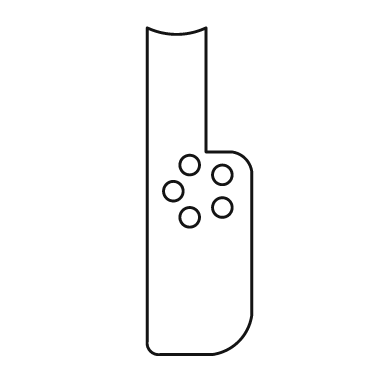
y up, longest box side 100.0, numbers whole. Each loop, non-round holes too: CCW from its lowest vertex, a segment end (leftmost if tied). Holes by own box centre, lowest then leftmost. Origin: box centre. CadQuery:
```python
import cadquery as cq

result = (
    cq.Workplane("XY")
    .moveTo(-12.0, -50.0)
    .lineTo(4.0, -50.0)
    .threePointArc((12.0, -46.0), (16.0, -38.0))
    .lineTo(16.0, 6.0)
    .threePointArc((14.0, 10.0), (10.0, 12.0))
    .lineTo(2.0, 12.0)
    .lineTo(2.0, 50.0)
    .threePointArc((-7.0, 48.0), (-16.0, 50.0))
    .lineTo(-16.0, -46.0)
    .threePointArc((-15.0, -49.0), (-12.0, -50.0))
    .close()
    .moveTo(-3.0, -8.0)
    .circle(3.0)
    .moveTo(7.0, -5.0)
    .circle(3.0)
    .moveTo(-8.0, 0.0)
    .circle(3.0)
    .moveTo(7.0, 5.0)
    .circle(3.0)
    .moveTo(-3.0, 8.0)
    .circle(3.0)
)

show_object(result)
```